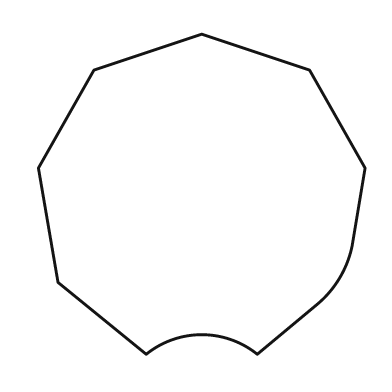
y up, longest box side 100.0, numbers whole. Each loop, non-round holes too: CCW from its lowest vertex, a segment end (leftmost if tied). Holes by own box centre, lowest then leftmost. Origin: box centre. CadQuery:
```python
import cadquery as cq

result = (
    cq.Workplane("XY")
    .moveTo(-17.0, -49.0)
    .threePointArc((0.0, -43.0), (17.0, -49.0))
    .lineTo(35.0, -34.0)
    .threePointArc((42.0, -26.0), (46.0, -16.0))
    .lineTo(50.0, 8.0)
    .lineTo(33.0, 38.0)
    .lineTo(0.0, 49.0)
    .lineTo(-33.0, 38.0)
    .lineTo(-50.0, 8.0)
    .lineTo(-44.0, -27.0)
    .close()
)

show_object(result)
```